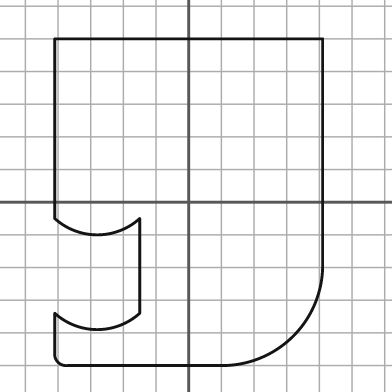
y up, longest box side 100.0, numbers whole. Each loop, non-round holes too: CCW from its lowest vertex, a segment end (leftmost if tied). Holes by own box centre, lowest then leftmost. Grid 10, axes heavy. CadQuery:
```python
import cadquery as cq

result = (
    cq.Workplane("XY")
    .moveTo(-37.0, -50.0)
    .lineTo(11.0, -50.0)
    .threePointArc((32.0, -41.0), (41.0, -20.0))
    .lineTo(41.0, 50.0)
    .lineTo(-41.0, 50.0)
    .lineTo(-41.0, -5.0)
    .threePointArc((-28.0, -10.0), (-15.0, -5.0))
    .lineTo(-15.0, -34.0)
    .threePointArc((-28.0, -39.0), (-41.0, -34.0))
    .lineTo(-41.0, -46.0)
    .threePointArc((-40.0, -49.0), (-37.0, -50.0))
    .close()
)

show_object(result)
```